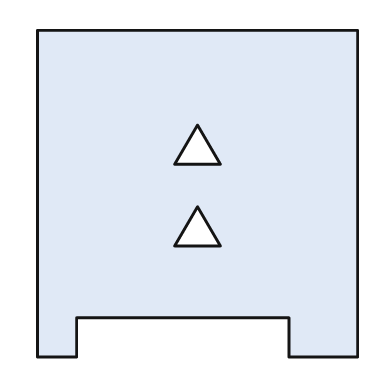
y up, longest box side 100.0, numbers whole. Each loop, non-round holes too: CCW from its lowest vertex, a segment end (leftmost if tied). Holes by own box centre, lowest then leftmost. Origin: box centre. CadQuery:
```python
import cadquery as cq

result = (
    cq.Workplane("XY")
    .moveTo(-49.0, -50.0)
    .lineTo(-37.0, -50.0)
    .lineTo(-37.0, -38.0)
    .lineTo(28.0, -38.0)
    .lineTo(28.0, -50.0)
    .lineTo(49.0, -50.0)
    .lineTo(49.0, 50.0)
    .lineTo(-49.0, 50.0)
    .close()
    .moveTo(-7.0, -16.0)
    .lineTo(7.0, -16.0)
    .lineTo(0.0, -4.0)
    .close()
    .moveTo(-7.0, 9.0)
    .lineTo(7.0, 9.0)
    .lineTo(0.0, 21.0)
    .close()
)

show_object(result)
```